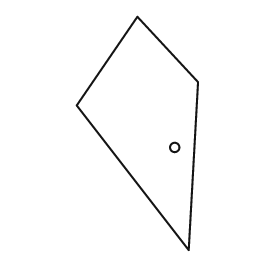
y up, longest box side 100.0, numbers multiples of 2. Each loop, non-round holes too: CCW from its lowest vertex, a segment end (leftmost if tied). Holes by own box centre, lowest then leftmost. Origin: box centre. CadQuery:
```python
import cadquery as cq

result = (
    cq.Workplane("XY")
    .moveTo(22.0, -50.0)
    .lineTo(26.0, 22.0)
    .lineTo(0.0, 50.0)
    .lineTo(-26.0, 12.0)
    .close()
    .moveTo(16.0, -6.0)
    .circle(2.0)
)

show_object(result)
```